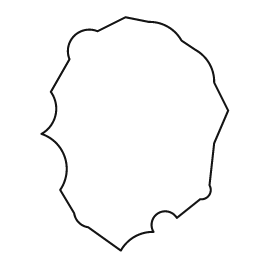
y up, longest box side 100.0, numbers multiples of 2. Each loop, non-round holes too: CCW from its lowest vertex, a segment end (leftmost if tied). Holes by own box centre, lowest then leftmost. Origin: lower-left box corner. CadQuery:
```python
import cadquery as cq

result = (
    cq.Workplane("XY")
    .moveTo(34.0, 0.0)
    .threePointArc((40.0, 6.0), (48.0, 8.0))
    .threePointArc((50.0, 16.0), (58.0, 14.0))
    .lineTo(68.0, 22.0)
    .threePointArc((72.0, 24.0), (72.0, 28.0))
    .lineTo(74.0, 46.0)
    .lineTo(80.0, 60.0)
    .lineTo(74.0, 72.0)
    .threePointArc((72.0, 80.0), (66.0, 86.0))
    .lineTo(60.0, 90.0)
    .threePointArc((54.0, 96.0), (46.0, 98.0))
    .lineTo(36.0, 100.0)
    .lineTo(24.0, 94.0)
    .threePointArc((14.0, 92.0), (12.0, 82.0))
    .lineTo(4.0, 68.0)
    .threePointArc((6.0, 58.0), (0.0, 50.0))
    .threePointArc((10.0, 40.0), (8.0, 26.0))
    .lineTo(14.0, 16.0)
    .threePointArc((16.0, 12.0), (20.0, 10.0))
    .close()
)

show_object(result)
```